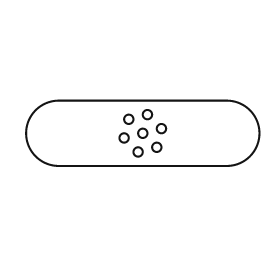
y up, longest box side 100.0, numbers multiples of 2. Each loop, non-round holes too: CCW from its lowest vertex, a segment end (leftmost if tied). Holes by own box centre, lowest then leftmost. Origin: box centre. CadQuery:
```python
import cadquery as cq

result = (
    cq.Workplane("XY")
    .moveTo(-36.0, -14.0)
    .lineTo(36.0, -14.0)
    .threePointArc((50.0, 0.0), (36.0, 14.0))
    .lineTo(-36.0, 14.0)
    .threePointArc((-50.0, 0.0), (-36.0, -14.0))
    .close()
    .moveTo(-2.0, -8.0)
    .circle(2.0)
    .moveTo(6.0, -6.0)
    .circle(2.0)
    .moveTo(-8.0, -2.0)
    .circle(2.0)
    .moveTo(0.0, 0.0)
    .circle(2.0)
    .moveTo(8.0, 2.0)
    .circle(2.0)
    .moveTo(-6.0, 6.0)
    .circle(2.0)
    .moveTo(2.0, 8.0)
    .circle(2.0)
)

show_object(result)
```